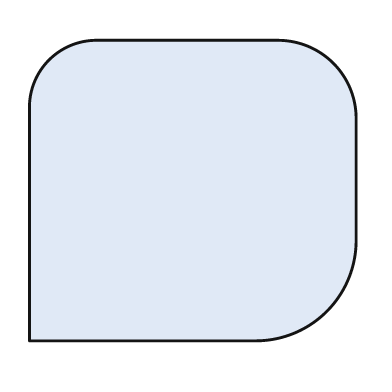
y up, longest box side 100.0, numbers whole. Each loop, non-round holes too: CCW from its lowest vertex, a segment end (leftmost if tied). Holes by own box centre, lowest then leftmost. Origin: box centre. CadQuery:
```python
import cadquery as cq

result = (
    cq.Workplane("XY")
    .moveTo(-50.0, -46.0)
    .lineTo(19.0, -46.0)
    .threePointArc((41.0, -37.0), (50.0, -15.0))
    .lineTo(50.0, 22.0)
    .threePointArc((43.0, 39.0), (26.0, 46.0))
    .lineTo(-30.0, 46.0)
    .threePointArc((-44.0, 40.0), (-50.0, 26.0))
    .close()
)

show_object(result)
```